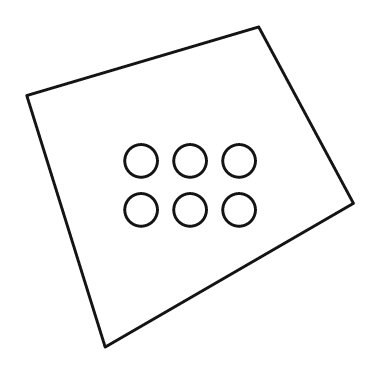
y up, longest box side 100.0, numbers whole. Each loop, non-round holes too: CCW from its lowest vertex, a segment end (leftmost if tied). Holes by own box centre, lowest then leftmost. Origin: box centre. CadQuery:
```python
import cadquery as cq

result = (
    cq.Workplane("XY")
    .moveTo(-26.0, -49.0)
    .lineTo(50.0, -5.0)
    .lineTo(21.0, 49.0)
    .lineTo(-50.0, 28.0)
    .close()
    .moveTo(-15.0, -7.0)
    .circle(5.0)
    .moveTo(0.0, -7.0)
    .circle(5.0)
    .moveTo(15.0, -7.0)
    .circle(5.0)
    .moveTo(-15.0, 8.0)
    .circle(5.0)
    .moveTo(0.0, 8.0)
    .circle(5.0)
    .moveTo(15.0, 8.0)
    .circle(5.0)
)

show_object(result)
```